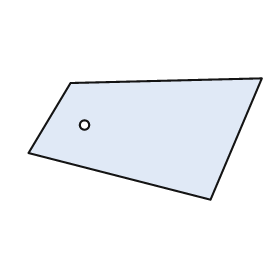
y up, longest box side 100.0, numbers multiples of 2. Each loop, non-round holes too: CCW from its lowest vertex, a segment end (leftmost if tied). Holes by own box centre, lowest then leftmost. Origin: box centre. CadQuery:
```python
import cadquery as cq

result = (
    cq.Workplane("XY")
    .moveTo(28.0, -26.0)
    .lineTo(50.0, 26.0)
    .lineTo(-32.0, 24.0)
    .lineTo(-50.0, -6.0)
    .close()
    .moveTo(-26.0, 6.0)
    .circle(2.0)
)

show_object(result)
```